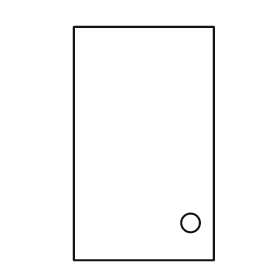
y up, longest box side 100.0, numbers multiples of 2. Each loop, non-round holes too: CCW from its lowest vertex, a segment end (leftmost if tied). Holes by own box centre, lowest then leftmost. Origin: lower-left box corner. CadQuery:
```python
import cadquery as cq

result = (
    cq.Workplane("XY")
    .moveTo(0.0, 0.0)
    .lineTo(60.0, 0.0)
    .lineTo(60.0, 100.0)
    .lineTo(0.0, 100.0)
    .close()
    .moveTo(50.0, 16.0)
    .circle(4.0)
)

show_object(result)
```